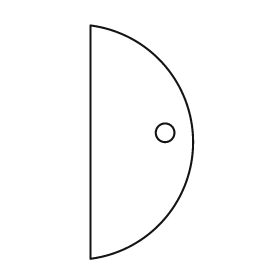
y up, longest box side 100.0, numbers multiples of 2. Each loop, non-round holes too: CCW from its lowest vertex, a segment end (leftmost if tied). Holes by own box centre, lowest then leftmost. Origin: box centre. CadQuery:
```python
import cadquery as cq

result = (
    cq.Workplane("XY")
    .moveTo(-22.0, -50.0)
    .threePointArc((22.0, 0.0), (-22.0, 50.0))
    .close()
    .moveTo(10.0, 4.0)
    .circle(4.0)
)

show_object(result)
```